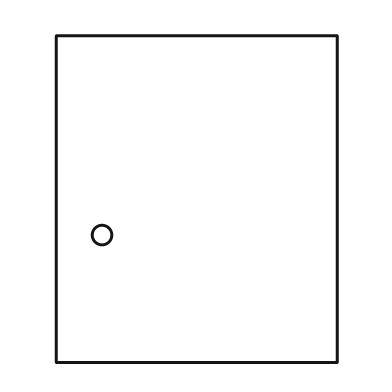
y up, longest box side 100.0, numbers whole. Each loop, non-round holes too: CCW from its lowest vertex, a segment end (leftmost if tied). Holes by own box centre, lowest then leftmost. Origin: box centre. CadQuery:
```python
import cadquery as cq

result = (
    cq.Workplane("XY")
    .moveTo(-43.0, -50.0)
    .lineTo(43.0, -50.0)
    .lineTo(43.0, 50.0)
    .lineTo(-43.0, 50.0)
    .close()
    .moveTo(-29.0, -11.0)
    .circle(3.0)
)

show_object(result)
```